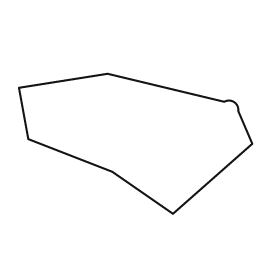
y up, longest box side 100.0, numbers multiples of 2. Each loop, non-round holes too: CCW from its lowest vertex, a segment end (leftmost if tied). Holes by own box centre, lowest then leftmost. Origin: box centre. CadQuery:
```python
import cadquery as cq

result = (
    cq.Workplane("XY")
    .moveTo(16.0, -30.0)
    .lineTo(50.0, 0.0)
    .lineTo(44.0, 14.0)
    .threePointArc((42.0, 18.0), (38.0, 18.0))
    .lineTo(-12.0, 30.0)
    .lineTo(-50.0, 24.0)
    .lineTo(-46.0, 2.0)
    .lineTo(-10.0, -12.0)
    .close()
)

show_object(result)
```